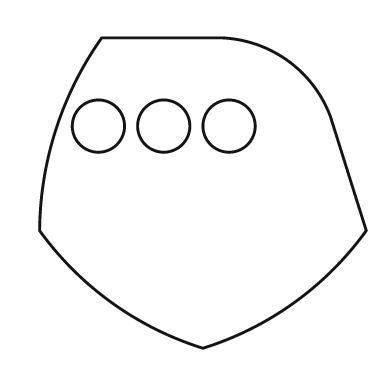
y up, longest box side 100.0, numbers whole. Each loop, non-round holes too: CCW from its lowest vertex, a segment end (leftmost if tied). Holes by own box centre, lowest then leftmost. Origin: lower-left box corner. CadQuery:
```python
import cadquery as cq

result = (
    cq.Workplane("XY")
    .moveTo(50.0, 0.0)
    .threePointArc((78.0, 14.0), (100.0, 36.0))
    .lineTo(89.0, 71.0)
    .threePointArc((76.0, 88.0), (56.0, 95.0))
    .lineTo(19.0, 95.0)
    .threePointArc((5.0, 67.0), (0.0, 36.0))
    .threePointArc((22.0, 14.0), (50.0, 0.0))
    .close()
    .moveTo(18.0, 68.0)
    .circle(8.0)
    .moveTo(38.0, 68.0)
    .circle(8.0)
    .moveTo(58.0, 68.0)
    .circle(8.0)
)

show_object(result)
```